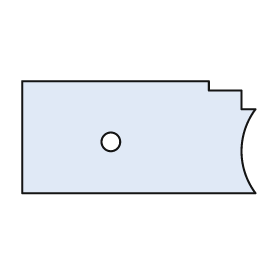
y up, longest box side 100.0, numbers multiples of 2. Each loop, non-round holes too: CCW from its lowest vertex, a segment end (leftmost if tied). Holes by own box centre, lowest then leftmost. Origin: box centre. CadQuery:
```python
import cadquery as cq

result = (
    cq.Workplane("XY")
    .moveTo(-50.0, -24.0)
    .lineTo(50.0, -24.0)
    .threePointArc((44.0, -6.0), (50.0, 12.0))
    .lineTo(44.0, 12.0)
    .lineTo(44.0, 20.0)
    .lineTo(30.0, 20.0)
    .lineTo(30.0, 24.0)
    .lineTo(-50.0, 24.0)
    .close()
    .moveTo(-12.0, -2.0)
    .circle(4.0)
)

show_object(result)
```